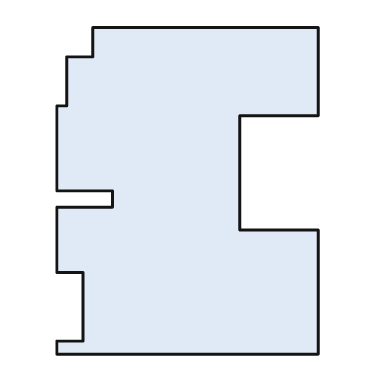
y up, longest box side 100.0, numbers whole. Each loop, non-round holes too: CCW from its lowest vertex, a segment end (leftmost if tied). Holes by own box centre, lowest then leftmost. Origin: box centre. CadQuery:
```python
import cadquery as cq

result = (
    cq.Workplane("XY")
    .moveTo(-40.0, -50.0)
    .lineTo(40.0, -50.0)
    .lineTo(40.0, -12.0)
    .lineTo(16.0, -12.0)
    .lineTo(16.0, 23.0)
    .lineTo(40.0, 23.0)
    .lineTo(40.0, 50.0)
    .lineTo(-29.0, 50.0)
    .lineTo(-29.0, 41.0)
    .lineTo(-37.0, 41.0)
    .lineTo(-37.0, 26.0)
    .lineTo(-40.0, 26.0)
    .lineTo(-40.0, 0.0)
    .lineTo(-23.0, 0.0)
    .lineTo(-23.0, -5.0)
    .lineTo(-40.0, -5.0)
    .lineTo(-40.0, -25.0)
    .lineTo(-32.0, -25.0)
    .lineTo(-32.0, -46.0)
    .lineTo(-40.0, -46.0)
    .close()
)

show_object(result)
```